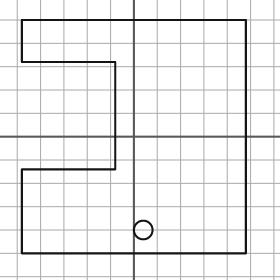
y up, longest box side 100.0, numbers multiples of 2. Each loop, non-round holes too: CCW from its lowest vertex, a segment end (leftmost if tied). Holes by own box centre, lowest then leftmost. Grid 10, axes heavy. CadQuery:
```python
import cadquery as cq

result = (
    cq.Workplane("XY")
    .moveTo(-48.0, -50.0)
    .lineTo(48.0, -50.0)
    .lineTo(48.0, 50.0)
    .lineTo(-48.0, 50.0)
    .lineTo(-48.0, 32.0)
    .lineTo(-8.0, 32.0)
    .lineTo(-8.0, -14.0)
    .lineTo(-48.0, -14.0)
    .close()
    .moveTo(4.0, -40.0)
    .circle(4.0)
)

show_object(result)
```